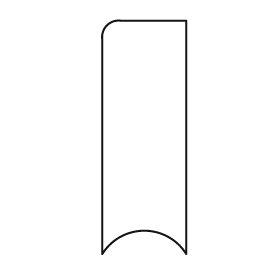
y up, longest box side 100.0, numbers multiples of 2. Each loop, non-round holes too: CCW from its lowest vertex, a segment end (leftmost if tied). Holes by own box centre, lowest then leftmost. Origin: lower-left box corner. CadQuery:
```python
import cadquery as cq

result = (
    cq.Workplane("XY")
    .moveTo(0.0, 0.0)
    .threePointArc((18.0, 10.0), (36.0, 0.0))
    .lineTo(36.0, 100.0)
    .lineTo(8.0, 100.0)
    .threePointArc((2.0, 98.0), (0.0, 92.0))
    .close()
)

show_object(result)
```